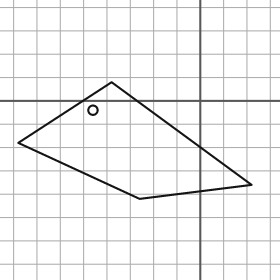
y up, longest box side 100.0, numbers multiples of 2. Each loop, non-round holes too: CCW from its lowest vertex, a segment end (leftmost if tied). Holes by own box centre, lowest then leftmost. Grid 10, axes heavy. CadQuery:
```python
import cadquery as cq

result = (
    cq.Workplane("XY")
    .moveTo(-26.0, -42.0)
    .lineTo(22.0, -36.0)
    .lineTo(-38.0, 8.0)
    .lineTo(-78.0, -18.0)
    .close()
    .moveTo(-46.0, -4.0)
    .circle(2.0)
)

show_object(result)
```